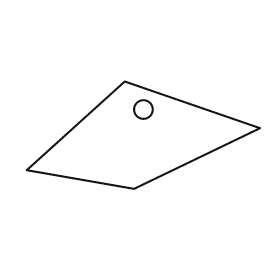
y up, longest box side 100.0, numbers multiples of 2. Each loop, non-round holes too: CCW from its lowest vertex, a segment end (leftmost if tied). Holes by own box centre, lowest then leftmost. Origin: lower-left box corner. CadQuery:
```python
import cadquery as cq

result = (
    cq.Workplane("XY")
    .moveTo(46.0, 0.0)
    .lineTo(100.0, 26.0)
    .lineTo(42.0, 46.0)
    .lineTo(0.0, 8.0)
    .close()
    .moveTo(50.0, 34.0)
    .circle(4.0)
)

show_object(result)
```